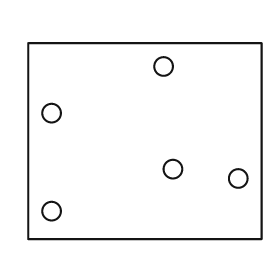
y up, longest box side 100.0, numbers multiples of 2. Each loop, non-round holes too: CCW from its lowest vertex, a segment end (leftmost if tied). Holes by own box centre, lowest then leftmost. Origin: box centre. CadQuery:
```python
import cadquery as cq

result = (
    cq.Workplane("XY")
    .moveTo(-50.0, -42.0)
    .lineTo(50.0, -42.0)
    .lineTo(50.0, 42.0)
    .lineTo(-50.0, 42.0)
    .close()
    .moveTo(-40.0, -30.0)
    .circle(4.0)
    .moveTo(40.0, -16.0)
    .circle(4.0)
    .moveTo(12.0, -12.0)
    .circle(4.0)
    .moveTo(-40.0, 12.0)
    .circle(4.0)
    .moveTo(8.0, 32.0)
    .circle(4.0)
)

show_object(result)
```